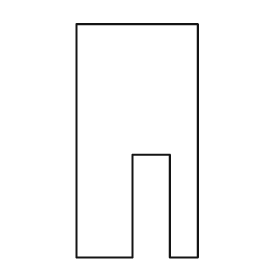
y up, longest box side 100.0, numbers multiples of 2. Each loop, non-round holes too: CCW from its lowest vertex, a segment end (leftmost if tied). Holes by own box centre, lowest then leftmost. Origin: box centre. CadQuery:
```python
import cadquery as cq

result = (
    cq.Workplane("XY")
    .moveTo(-26.0, -50.0)
    .lineTo(-2.0, -50.0)
    .lineTo(-2.0, -6.0)
    .lineTo(14.0, -6.0)
    .lineTo(14.0, -50.0)
    .lineTo(26.0, -50.0)
    .lineTo(26.0, 50.0)
    .lineTo(-26.0, 50.0)
    .close()
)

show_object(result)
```